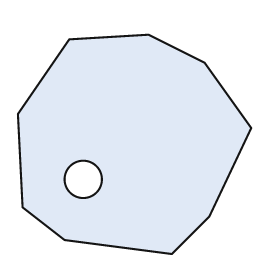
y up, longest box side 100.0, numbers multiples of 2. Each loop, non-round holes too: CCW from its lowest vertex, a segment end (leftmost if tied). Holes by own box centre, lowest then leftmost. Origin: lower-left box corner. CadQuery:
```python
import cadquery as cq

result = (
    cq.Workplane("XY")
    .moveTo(66.0, 0.0)
    .lineTo(82.0, 16.0)
    .lineTo(100.0, 54.0)
    .lineTo(80.0, 82.0)
    .lineTo(56.0, 94.0)
    .lineTo(22.0, 92.0)
    .lineTo(0.0, 60.0)
    .lineTo(2.0, 20.0)
    .lineTo(20.0, 6.0)
    .close()
    .moveTo(28.0, 32.0)
    .circle(8.0)
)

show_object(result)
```